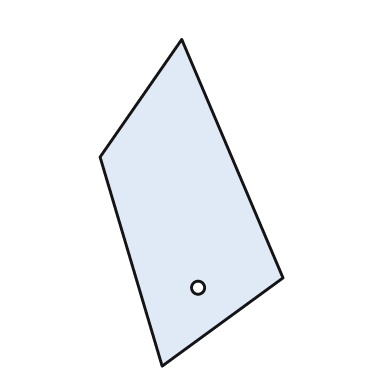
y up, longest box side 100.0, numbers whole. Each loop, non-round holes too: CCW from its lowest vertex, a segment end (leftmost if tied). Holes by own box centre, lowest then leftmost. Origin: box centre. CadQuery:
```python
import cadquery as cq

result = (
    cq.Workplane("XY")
    .moveTo(-9.0, -50.0)
    .lineTo(28.0, -23.0)
    .lineTo(-3.0, 50.0)
    .lineTo(-28.0, 14.0)
    .close()
    .moveTo(2.0, -26.0)
    .circle(2.0)
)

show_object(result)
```